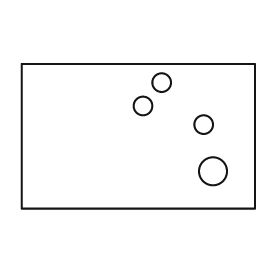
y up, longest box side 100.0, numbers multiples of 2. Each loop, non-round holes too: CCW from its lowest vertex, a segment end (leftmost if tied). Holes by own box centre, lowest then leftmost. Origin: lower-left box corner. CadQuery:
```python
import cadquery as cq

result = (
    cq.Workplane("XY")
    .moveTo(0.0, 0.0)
    .lineTo(100.0, 0.0)
    .lineTo(100.0, 62.0)
    .lineTo(0.0, 62.0)
    .close()
    .moveTo(82.0, 16.0)
    .circle(6.0)
    .moveTo(78.0, 36.0)
    .circle(4.0)
    .moveTo(52.0, 44.0)
    .circle(4.0)
    .moveTo(60.0, 54.0)
    .circle(4.0)
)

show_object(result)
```